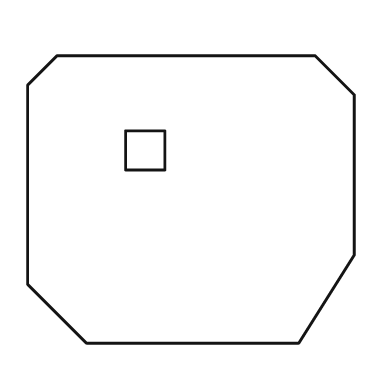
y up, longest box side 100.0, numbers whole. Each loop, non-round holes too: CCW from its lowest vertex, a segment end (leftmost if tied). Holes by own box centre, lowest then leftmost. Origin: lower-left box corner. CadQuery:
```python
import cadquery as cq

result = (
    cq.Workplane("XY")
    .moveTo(18.0, 0.0)
    .lineTo(83.0, 0.0)
    .lineTo(100.0, 27.0)
    .lineTo(100.0, 76.0)
    .lineTo(88.0, 88.0)
    .lineTo(9.0, 88.0)
    .lineTo(0.0, 79.0)
    .lineTo(0.0, 18.0)
    .close()
    .moveTo(30.0, 53.0)
    .lineTo(42.0, 53.0)
    .lineTo(42.0, 65.0)
    .lineTo(30.0, 65.0)
    .close()
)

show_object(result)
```